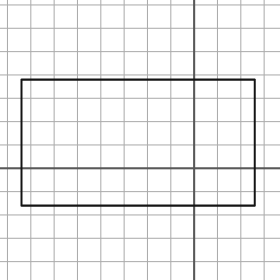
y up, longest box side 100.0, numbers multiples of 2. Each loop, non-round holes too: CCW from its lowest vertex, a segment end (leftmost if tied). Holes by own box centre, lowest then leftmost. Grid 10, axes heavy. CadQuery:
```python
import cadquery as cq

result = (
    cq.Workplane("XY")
    .moveTo(-74.0, -16.0)
    .lineTo(26.0, -16.0)
    .lineTo(26.0, 38.0)
    .lineTo(-74.0, 38.0)
    .close()
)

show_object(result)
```